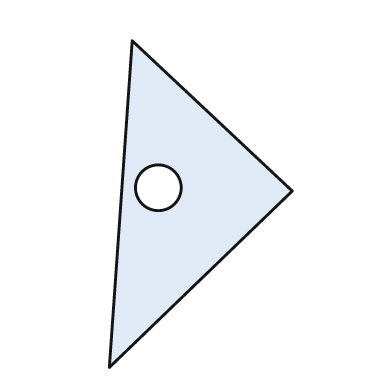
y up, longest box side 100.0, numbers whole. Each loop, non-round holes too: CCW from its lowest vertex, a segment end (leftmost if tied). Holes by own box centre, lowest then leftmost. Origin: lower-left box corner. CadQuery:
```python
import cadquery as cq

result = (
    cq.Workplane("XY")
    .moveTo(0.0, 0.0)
    .lineTo(56.0, 54.0)
    .lineTo(7.0, 100.0)
    .close()
    .moveTo(15.0, 55.0)
    .circle(7.0)
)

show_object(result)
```